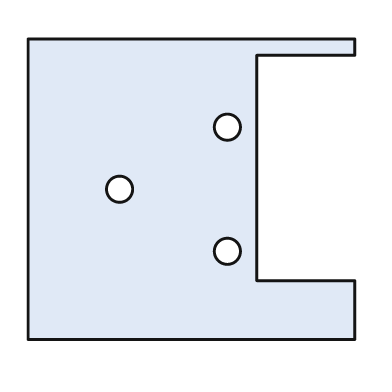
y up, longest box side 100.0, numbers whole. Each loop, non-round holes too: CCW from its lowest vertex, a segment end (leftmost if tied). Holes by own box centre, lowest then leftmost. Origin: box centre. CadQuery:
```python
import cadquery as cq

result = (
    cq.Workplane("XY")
    .moveTo(-50.0, -46.0)
    .lineTo(50.0, -46.0)
    .lineTo(50.0, -28.0)
    .lineTo(20.0, -28.0)
    .lineTo(20.0, 41.0)
    .lineTo(50.0, 41.0)
    .lineTo(50.0, 46.0)
    .lineTo(-50.0, 46.0)
    .close()
    .moveTo(11.0, -19.0)
    .circle(4.0)
    .moveTo(-22.0, 0.0)
    .circle(4.0)
    .moveTo(11.0, 19.0)
    .circle(4.0)
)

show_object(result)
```